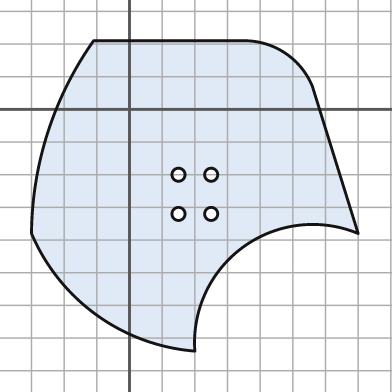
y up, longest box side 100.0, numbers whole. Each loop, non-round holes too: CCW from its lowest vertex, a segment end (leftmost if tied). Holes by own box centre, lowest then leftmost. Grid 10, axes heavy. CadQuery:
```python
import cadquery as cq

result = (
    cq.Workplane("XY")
    .moveTo(20.0, -74.0)
    .threePointArc((35.0, -42.0), (70.0, -38.0))
    .lineTo(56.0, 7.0)
    .threePointArc((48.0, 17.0), (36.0, 21.0))
    .lineTo(-11.0, 21.0)
    .threePointArc((-25.0, -7.0), (-30.0, -38.0))
    .threePointArc((-10.0, -63.0), (20.0, -74.0))
    .close()
    .moveTo(15.0, -32.0)
    .circle(2.0)
    .moveTo(25.0, -32.0)
    .circle(2.0)
    .moveTo(15.0, -20.0)
    .circle(2.0)
    .moveTo(25.0, -20.0)
    .circle(2.0)
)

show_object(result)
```